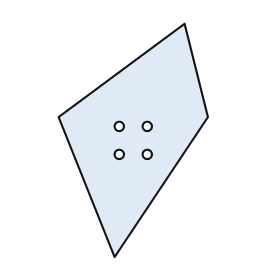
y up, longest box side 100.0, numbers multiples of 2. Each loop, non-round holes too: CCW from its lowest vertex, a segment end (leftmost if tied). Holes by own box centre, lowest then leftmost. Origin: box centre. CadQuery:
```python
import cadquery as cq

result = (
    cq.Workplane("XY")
    .moveTo(-8.0, -50.0)
    .lineTo(32.0, 10.0)
    .lineTo(22.0, 50.0)
    .lineTo(-32.0, 10.0)
    .close()
    .moveTo(-6.0, -6.0)
    .circle(2.0)
    .moveTo(6.0, -6.0)
    .circle(2.0)
    .moveTo(-6.0, 6.0)
    .circle(2.0)
    .moveTo(6.0, 6.0)
    .circle(2.0)
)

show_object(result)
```